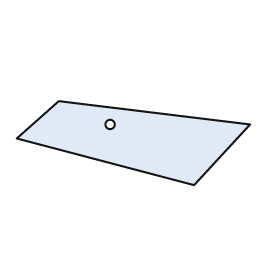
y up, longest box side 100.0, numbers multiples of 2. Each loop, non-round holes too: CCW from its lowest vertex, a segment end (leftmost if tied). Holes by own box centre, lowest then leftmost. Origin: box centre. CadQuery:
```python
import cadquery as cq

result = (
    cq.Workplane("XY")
    .moveTo(26.0, -18.0)
    .lineTo(50.0, 8.0)
    .lineTo(-32.0, 18.0)
    .lineTo(-50.0, 2.0)
    .close()
    .moveTo(-10.0, 8.0)
    .circle(2.0)
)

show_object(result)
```